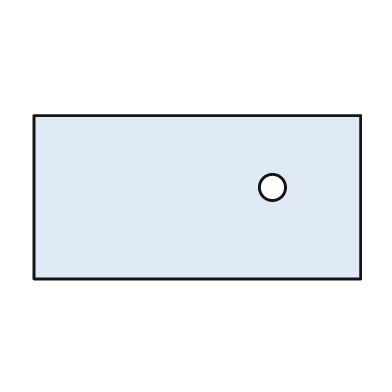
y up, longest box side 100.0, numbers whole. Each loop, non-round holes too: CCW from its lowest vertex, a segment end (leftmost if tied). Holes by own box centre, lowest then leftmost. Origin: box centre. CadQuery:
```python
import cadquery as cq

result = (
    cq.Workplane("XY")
    .moveTo(-50.0, -25.0)
    .lineTo(50.0, -25.0)
    .lineTo(50.0, 25.0)
    .lineTo(-50.0, 25.0)
    .close()
    .moveTo(23.0, 3.0)
    .circle(4.0)
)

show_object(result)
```